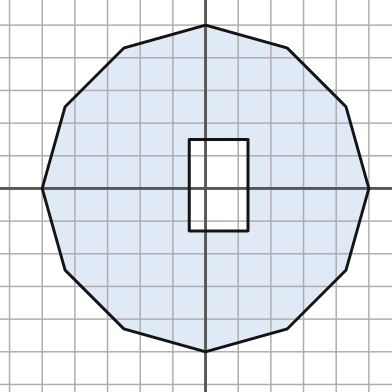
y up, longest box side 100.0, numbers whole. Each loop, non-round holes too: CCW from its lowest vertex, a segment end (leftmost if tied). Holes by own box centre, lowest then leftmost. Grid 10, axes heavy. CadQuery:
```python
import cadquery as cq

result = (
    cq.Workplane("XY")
    .moveTo(0.0, -50.0)
    .lineTo(25.0, -43.0)
    .lineTo(43.0, -25.0)
    .lineTo(50.0, 0.0)
    .lineTo(43.0, 25.0)
    .lineTo(25.0, 43.0)
    .lineTo(0.0, 50.0)
    .lineTo(-25.0, 43.0)
    .lineTo(-43.0, 25.0)
    .lineTo(-50.0, 0.0)
    .lineTo(-43.0, -25.0)
    .lineTo(-25.0, -43.0)
    .close()
    .moveTo(-5.0, -13.0)
    .lineTo(13.0, -13.0)
    .lineTo(13.0, 15.0)
    .lineTo(-5.0, 15.0)
    .close()
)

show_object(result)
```